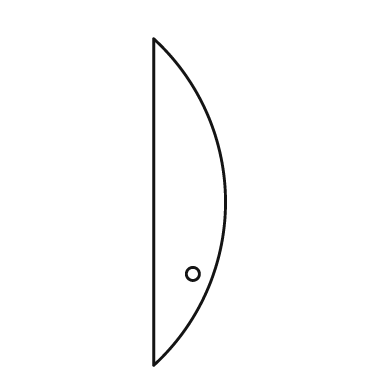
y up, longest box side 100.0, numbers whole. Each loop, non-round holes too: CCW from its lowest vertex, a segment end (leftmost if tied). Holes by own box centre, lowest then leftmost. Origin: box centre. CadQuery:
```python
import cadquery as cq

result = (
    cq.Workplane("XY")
    .moveTo(-11.0, -50.0)
    .threePointArc((11.0, 0.0), (-11.0, 50.0))
    .close()
    .moveTo(1.0, -22.0)
    .circle(2.0)
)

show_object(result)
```